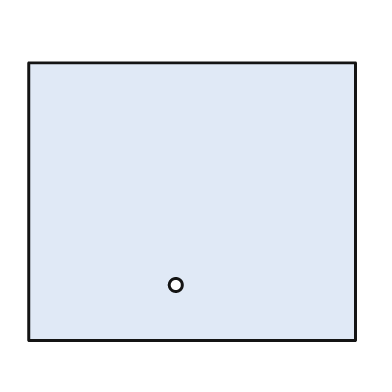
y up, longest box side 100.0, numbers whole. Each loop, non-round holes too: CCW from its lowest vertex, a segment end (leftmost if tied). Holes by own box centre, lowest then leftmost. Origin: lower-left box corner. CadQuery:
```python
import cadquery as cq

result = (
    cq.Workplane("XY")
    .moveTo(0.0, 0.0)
    .lineTo(100.0, 0.0)
    .lineTo(100.0, 85.0)
    .lineTo(0.0, 85.0)
    .close()
    .moveTo(45.0, 17.0)
    .circle(2.0)
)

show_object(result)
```